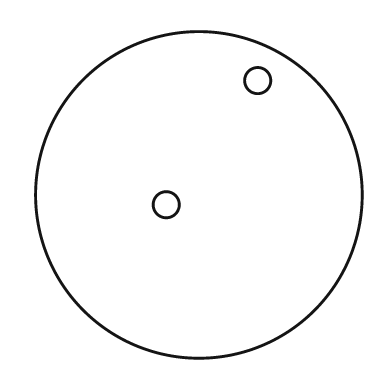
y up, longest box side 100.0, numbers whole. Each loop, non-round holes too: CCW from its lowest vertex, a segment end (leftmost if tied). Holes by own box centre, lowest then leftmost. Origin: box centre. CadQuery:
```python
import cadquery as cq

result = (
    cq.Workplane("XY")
    .moveTo(0.0, 0.0)
    .circle(50.0)
    .moveTo(-10.0, -3.0)
    .circle(4.0)
    .moveTo(18.0, 35.0)
    .circle(4.0)
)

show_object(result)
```